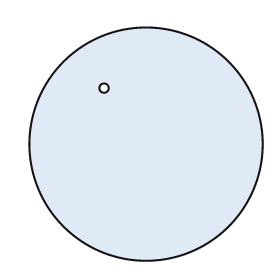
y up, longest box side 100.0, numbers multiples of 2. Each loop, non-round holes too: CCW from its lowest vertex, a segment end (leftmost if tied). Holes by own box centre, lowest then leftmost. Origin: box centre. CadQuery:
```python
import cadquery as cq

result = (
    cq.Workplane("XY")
    .moveTo(0.0, 0.0)
    .circle(50.0)
    .moveTo(-18.0, 24.0)
    .circle(2.0)
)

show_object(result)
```